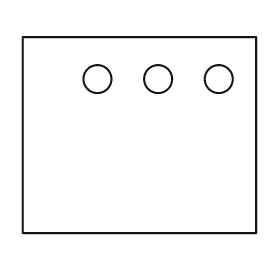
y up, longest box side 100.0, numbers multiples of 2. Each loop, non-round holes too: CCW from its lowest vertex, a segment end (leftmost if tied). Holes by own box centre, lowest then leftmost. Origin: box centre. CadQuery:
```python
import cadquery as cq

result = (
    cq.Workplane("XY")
    .moveTo(-50.0, -42.0)
    .lineTo(50.0, -42.0)
    .lineTo(50.0, 42.0)
    .lineTo(-50.0, 42.0)
    .close()
    .moveTo(-18.0, 24.0)
    .circle(6.0)
    .moveTo(8.0, 24.0)
    .circle(6.0)
    .moveTo(34.0, 24.0)
    .circle(6.0)
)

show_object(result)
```